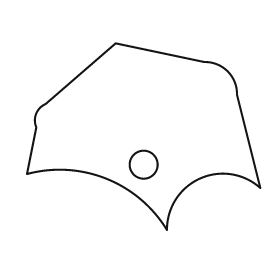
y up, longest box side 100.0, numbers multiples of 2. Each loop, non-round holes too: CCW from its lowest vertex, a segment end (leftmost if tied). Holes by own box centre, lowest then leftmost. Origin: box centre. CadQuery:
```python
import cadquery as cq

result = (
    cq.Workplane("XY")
    .moveTo(10.0, -40.0)
    .threePointArc((24.0, -18.0), (50.0, -22.0))
    .lineTo(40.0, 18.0)
    .threePointArc((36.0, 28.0), (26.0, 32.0))
    .lineTo(-12.0, 40.0)
    .lineTo(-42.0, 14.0)
    .threePointArc((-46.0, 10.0), (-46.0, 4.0))
    .lineTo(-50.0, -16.0)
    .threePointArc((-16.0, -18.0), (10.0, -40.0))
    .close()
    .moveTo(0.0, -12.0)
    .circle(6.0)
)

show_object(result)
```